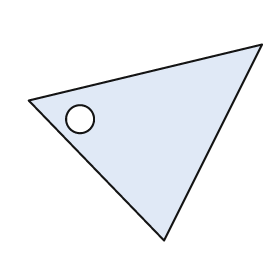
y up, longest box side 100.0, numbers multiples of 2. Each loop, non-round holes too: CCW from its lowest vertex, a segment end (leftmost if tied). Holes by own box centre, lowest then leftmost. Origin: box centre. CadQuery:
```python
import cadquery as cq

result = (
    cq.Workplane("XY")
    .moveTo(8.0, -42.0)
    .lineTo(50.0, 42.0)
    .lineTo(-50.0, 18.0)
    .close()
    .moveTo(-28.0, 10.0)
    .circle(6.0)
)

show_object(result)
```